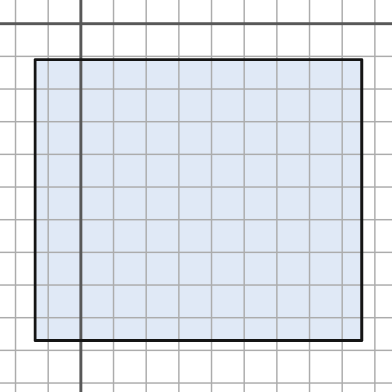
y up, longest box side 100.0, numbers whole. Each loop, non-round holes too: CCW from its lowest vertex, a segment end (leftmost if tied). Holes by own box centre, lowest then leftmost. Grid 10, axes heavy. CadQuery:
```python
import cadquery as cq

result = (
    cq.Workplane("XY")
    .moveTo(-14.0, -97.0)
    .lineTo(86.0, -97.0)
    .lineTo(86.0, -11.0)
    .lineTo(-14.0, -11.0)
    .close()
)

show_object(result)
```